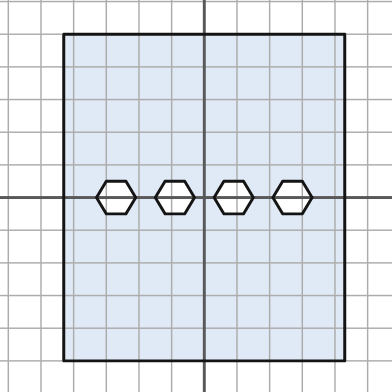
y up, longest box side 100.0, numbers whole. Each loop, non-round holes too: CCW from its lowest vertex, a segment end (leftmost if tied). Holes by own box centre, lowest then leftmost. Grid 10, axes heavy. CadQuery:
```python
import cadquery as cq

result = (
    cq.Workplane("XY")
    .moveTo(-43.0, -50.0)
    .lineTo(43.0, -50.0)
    .lineTo(43.0, 50.0)
    .lineTo(-43.0, 50.0)
    .close()
    .moveTo(-30.0, -5.0)
    .lineTo(-24.0, -5.0)
    .lineTo(-21.0, 0.0)
    .lineTo(-24.0, 5.0)
    .lineTo(-30.0, 5.0)
    .lineTo(-33.0, 0.0)
    .close()
    .moveTo(-12.0, -5.0)
    .lineTo(-6.0, -5.0)
    .lineTo(-3.0, 0.0)
    .lineTo(-6.0, 5.0)
    .lineTo(-12.0, 5.0)
    .lineTo(-15.0, 0.0)
    .close()
    .moveTo(6.0, -5.0)
    .lineTo(12.0, -5.0)
    .lineTo(15.0, 0.0)
    .lineTo(12.0, 5.0)
    .lineTo(6.0, 5.0)
    .lineTo(3.0, 0.0)
    .close()
    .moveTo(24.0, -5.0)
    .lineTo(30.0, -5.0)
    .lineTo(33.0, 0.0)
    .lineTo(30.0, 5.0)
    .lineTo(24.0, 5.0)
    .lineTo(21.0, 0.0)
    .close()
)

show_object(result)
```